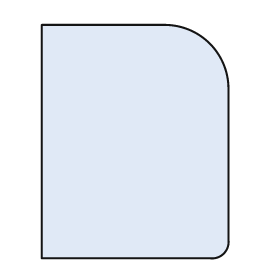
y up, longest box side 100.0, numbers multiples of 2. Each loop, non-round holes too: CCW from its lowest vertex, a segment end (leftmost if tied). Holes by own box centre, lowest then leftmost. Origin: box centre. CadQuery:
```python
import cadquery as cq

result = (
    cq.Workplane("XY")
    .moveTo(-40.0, -50.0)
    .lineTo(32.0, -50.0)
    .threePointArc((38.0, -48.0), (40.0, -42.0))
    .lineTo(40.0, 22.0)
    .threePointArc((32.0, 42.0), (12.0, 50.0))
    .lineTo(-40.0, 50.0)
    .close()
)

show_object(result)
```